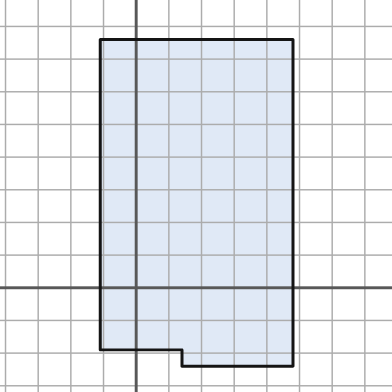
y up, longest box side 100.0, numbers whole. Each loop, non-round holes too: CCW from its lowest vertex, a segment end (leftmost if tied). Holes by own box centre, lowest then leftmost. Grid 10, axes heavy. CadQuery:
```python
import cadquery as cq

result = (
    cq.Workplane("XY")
    .moveTo(14.0, -24.0)
    .lineTo(48.0, -24.0)
    .lineTo(48.0, 76.0)
    .lineTo(-11.0, 76.0)
    .lineTo(-11.0, -19.0)
    .lineTo(14.0, -19.0)
    .close()
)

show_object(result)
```